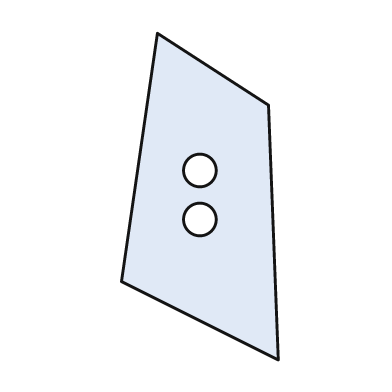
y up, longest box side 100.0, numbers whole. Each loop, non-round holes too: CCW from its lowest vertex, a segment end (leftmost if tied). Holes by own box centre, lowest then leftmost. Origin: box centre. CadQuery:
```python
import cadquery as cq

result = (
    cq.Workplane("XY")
    .moveTo(24.0, -50.0)
    .lineTo(21.0, 28.0)
    .lineTo(-13.0, 50.0)
    .lineTo(-24.0, -26.0)
    .close()
    .moveTo(0.0, -7.0)
    .circle(5.0)
    .moveTo(0.0, 8.0)
    .circle(5.0)
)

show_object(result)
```